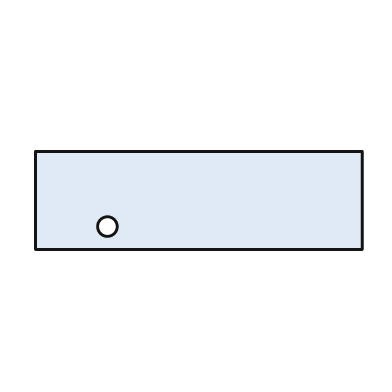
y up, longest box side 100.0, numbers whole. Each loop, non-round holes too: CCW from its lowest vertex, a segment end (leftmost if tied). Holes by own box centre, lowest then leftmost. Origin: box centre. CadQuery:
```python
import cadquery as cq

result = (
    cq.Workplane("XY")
    .moveTo(-50.0, -15.0)
    .lineTo(50.0, -15.0)
    .lineTo(50.0, 15.0)
    .lineTo(-50.0, 15.0)
    .close()
    .moveTo(-28.0, -8.0)
    .circle(3.0)
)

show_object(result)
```